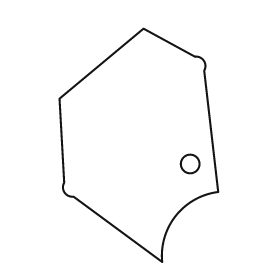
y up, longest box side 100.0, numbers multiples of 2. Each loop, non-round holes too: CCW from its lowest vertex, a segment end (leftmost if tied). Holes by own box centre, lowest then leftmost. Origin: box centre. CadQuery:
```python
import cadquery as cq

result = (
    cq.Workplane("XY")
    .moveTo(10.0, -50.0)
    .threePointArc((16.0, -30.0), (34.0, -20.0))
    .lineTo(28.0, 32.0)
    .threePointArc((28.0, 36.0), (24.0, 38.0))
    .lineTo(2.0, 50.0)
    .lineTo(-34.0, 20.0)
    .lineTo(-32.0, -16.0)
    .threePointArc((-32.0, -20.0), (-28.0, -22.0))
    .close()
    .moveTo(22.0, -8.0)
    .circle(4.0)
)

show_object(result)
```